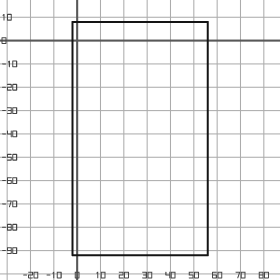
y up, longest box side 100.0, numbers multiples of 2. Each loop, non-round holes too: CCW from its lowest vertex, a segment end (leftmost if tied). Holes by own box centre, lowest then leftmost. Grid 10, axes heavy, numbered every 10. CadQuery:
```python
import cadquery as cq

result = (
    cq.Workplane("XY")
    .moveTo(-2.0, -92.0)
    .lineTo(56.0, -92.0)
    .lineTo(56.0, 8.0)
    .lineTo(-2.0, 8.0)
    .close()
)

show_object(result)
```